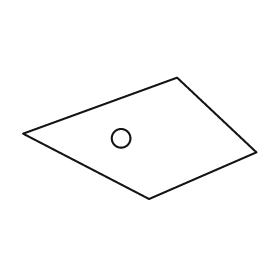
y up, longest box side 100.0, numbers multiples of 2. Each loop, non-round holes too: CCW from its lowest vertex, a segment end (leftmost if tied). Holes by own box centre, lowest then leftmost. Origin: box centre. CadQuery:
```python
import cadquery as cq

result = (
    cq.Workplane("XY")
    .moveTo(4.0, -26.0)
    .lineTo(50.0, -6.0)
    .lineTo(16.0, 26.0)
    .lineTo(-50.0, 2.0)
    .close()
    .moveTo(-8.0, 0.0)
    .circle(4.0)
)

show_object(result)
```